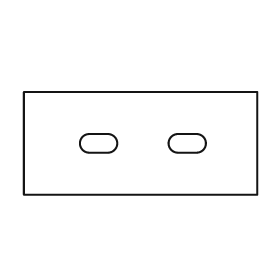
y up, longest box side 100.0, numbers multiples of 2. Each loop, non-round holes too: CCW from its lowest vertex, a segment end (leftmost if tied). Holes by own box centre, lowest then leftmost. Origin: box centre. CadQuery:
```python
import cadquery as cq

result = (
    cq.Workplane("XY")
    .moveTo(-50.0, -22.0)
    .lineTo(50.0, -22.0)
    .lineTo(50.0, 22.0)
    .lineTo(-50.0, 22.0)
    .close()
    .moveTo(-22.0, -4.0)
    .lineTo(-14.0, -4.0)
    .threePointArc((-10.0, 0.0), (-14.0, 4.0))
    .lineTo(-22.0, 4.0)
    .threePointArc((-26.0, 0.0), (-22.0, -4.0))
    .close()
    .moveTo(16.0, -4.0)
    .lineTo(24.0, -4.0)
    .threePointArc((28.0, 0.0), (24.0, 4.0))
    .lineTo(16.0, 4.0)
    .threePointArc((12.0, 0.0), (16.0, -4.0))
    .close()
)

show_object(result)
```